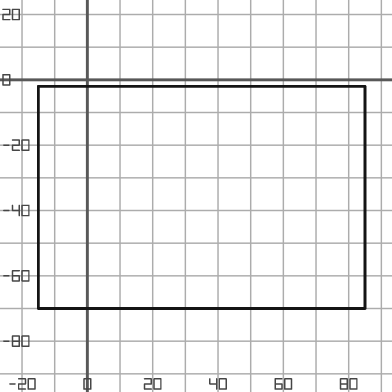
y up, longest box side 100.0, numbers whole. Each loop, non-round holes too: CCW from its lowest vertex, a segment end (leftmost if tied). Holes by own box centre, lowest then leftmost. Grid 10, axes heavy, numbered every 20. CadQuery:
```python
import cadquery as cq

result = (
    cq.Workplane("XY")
    .moveTo(-15.0, -70.0)
    .lineTo(85.0, -70.0)
    .lineTo(85.0, -2.0)
    .lineTo(-15.0, -2.0)
    .close()
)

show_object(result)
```